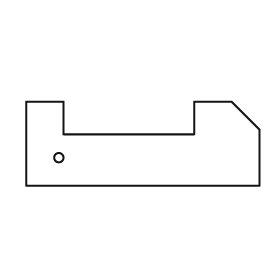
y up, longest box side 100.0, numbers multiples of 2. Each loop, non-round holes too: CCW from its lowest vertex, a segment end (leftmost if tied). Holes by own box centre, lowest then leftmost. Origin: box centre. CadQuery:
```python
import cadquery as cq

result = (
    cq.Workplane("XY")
    .moveTo(-50.0, -18.0)
    .lineTo(50.0, -18.0)
    .lineTo(50.0, 6.0)
    .lineTo(38.0, 18.0)
    .lineTo(22.0, 18.0)
    .lineTo(22.0, 4.0)
    .lineTo(-34.0, 4.0)
    .lineTo(-34.0, 18.0)
    .lineTo(-50.0, 18.0)
    .close()
    .moveTo(-36.0, -6.0)
    .circle(2.0)
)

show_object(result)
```